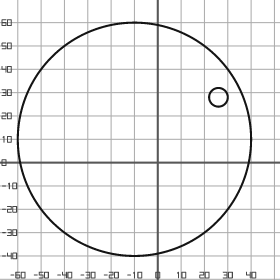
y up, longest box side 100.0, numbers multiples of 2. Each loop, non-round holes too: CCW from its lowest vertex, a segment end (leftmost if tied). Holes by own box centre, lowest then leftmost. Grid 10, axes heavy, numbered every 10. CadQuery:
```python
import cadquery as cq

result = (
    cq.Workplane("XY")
    .moveTo(-10.0, 10.0)
    .circle(50.0)
    .moveTo(26.0, 28.0)
    .circle(4.0)
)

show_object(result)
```